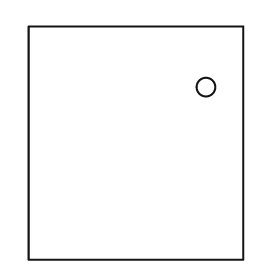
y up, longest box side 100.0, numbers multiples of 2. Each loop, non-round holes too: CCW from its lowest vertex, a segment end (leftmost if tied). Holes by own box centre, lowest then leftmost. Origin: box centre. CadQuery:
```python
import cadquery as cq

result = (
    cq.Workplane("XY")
    .moveTo(-46.0, -50.0)
    .lineTo(46.0, -50.0)
    .lineTo(46.0, 50.0)
    .lineTo(-46.0, 50.0)
    .close()
    .moveTo(30.0, 24.0)
    .circle(4.0)
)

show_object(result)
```